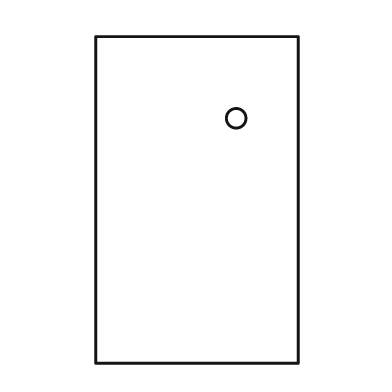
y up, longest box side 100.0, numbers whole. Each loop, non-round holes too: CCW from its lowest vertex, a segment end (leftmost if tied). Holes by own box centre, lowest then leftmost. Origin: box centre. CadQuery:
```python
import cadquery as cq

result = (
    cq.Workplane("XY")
    .moveTo(-31.0, -50.0)
    .lineTo(31.0, -50.0)
    .lineTo(31.0, 50.0)
    .lineTo(-31.0, 50.0)
    .close()
    .moveTo(12.0, 25.0)
    .circle(3.0)
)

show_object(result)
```